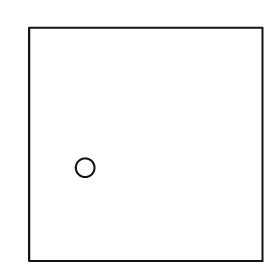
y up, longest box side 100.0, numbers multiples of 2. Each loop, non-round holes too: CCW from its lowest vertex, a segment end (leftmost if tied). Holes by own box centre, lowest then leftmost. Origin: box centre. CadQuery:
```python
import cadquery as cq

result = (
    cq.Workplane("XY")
    .moveTo(-50.0, -50.0)
    .lineTo(50.0, -50.0)
    .lineTo(50.0, 50.0)
    .lineTo(-50.0, 50.0)
    .close()
    .moveTo(-26.0, -10.0)
    .circle(4.0)
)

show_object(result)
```